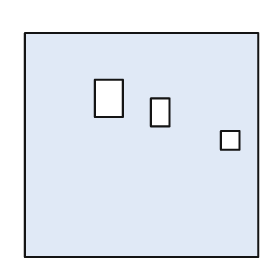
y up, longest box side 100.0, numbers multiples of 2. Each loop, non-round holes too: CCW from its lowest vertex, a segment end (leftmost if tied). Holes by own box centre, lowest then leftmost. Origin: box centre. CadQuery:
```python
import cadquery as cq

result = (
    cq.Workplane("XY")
    .moveTo(-50.0, -48.0)
    .lineTo(50.0, -48.0)
    .lineTo(50.0, 48.0)
    .lineTo(-50.0, 48.0)
    .close()
    .moveTo(34.0, -2.0)
    .lineTo(42.0, -2.0)
    .lineTo(42.0, 6.0)
    .lineTo(34.0, 6.0)
    .close()
    .moveTo(4.0, 8.0)
    .lineTo(12.0, 8.0)
    .lineTo(12.0, 20.0)
    .lineTo(4.0, 20.0)
    .close()
    .moveTo(-20.0, 12.0)
    .lineTo(-8.0, 12.0)
    .lineTo(-8.0, 28.0)
    .lineTo(-20.0, 28.0)
    .close()
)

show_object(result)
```